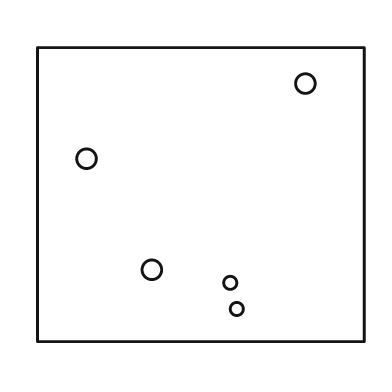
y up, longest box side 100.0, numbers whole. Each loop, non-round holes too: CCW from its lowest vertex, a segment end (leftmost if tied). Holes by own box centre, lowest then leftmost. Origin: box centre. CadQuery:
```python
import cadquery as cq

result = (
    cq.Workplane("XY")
    .moveTo(-50.0, -45.0)
    .lineTo(50.0, -45.0)
    .lineTo(50.0, 45.0)
    .lineTo(-50.0, 45.0)
    .close()
    .moveTo(11.0, -35.0)
    .circle(2.0)
    .moveTo(9.0, -27.0)
    .circle(2.0)
    .moveTo(-15.0, -23.0)
    .circle(3.0)
    .moveTo(-35.0, 11.0)
    .circle(3.0)
    .moveTo(32.0, 34.0)
    .circle(3.0)
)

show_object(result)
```